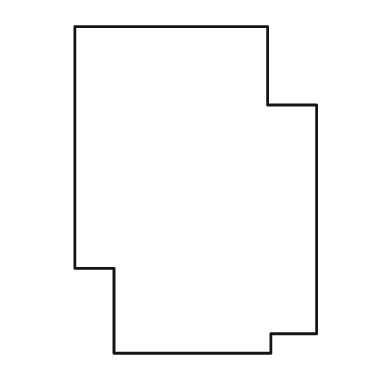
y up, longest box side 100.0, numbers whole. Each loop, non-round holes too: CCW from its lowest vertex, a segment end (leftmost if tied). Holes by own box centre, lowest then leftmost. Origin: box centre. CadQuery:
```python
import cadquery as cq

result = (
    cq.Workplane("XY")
    .moveTo(-25.0, -50.0)
    .lineTo(23.0, -50.0)
    .lineTo(23.0, -44.0)
    .lineTo(37.0, -44.0)
    .lineTo(37.0, 26.0)
    .lineTo(22.0, 26.0)
    .lineTo(22.0, 50.0)
    .lineTo(-37.0, 50.0)
    .lineTo(-37.0, -24.0)
    .lineTo(-25.0, -24.0)
    .close()
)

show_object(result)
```